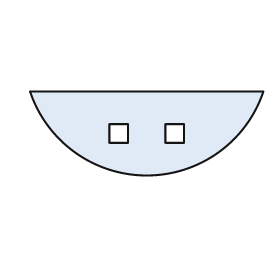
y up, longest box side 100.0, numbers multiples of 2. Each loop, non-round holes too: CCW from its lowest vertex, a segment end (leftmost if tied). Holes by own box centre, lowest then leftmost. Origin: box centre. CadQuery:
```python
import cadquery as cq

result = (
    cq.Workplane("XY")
    .moveTo(-50.0, 18.0)
    .threePointArc((0.0, -18.0), (50.0, 18.0))
    .close()
    .moveTo(-16.0, -4.0)
    .lineTo(-8.0, -4.0)
    .lineTo(-8.0, 4.0)
    .lineTo(-16.0, 4.0)
    .close()
    .moveTo(8.0, -4.0)
    .lineTo(16.0, -4.0)
    .lineTo(16.0, 4.0)
    .lineTo(8.0, 4.0)
    .close()
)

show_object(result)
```